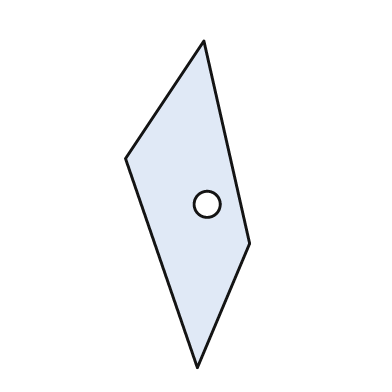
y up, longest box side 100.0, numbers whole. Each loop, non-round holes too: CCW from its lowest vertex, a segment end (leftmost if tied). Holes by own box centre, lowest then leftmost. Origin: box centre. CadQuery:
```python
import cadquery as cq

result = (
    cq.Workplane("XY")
    .moveTo(3.0, -50.0)
    .lineTo(19.0, -12.0)
    .lineTo(5.0, 50.0)
    .lineTo(-19.0, 14.0)
    .close()
    .moveTo(6.0, 0.0)
    .circle(4.0)
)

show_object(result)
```